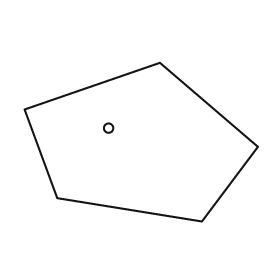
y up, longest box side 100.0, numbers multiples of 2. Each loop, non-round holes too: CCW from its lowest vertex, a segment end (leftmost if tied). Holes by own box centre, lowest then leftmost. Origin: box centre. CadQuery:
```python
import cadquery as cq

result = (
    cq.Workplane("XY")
    .moveTo(26.0, -34.0)
    .lineTo(50.0, -2.0)
    .lineTo(8.0, 34.0)
    .lineTo(-50.0, 14.0)
    .lineTo(-36.0, -24.0)
    .close()
    .moveTo(-14.0, 6.0)
    .circle(2.0)
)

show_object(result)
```